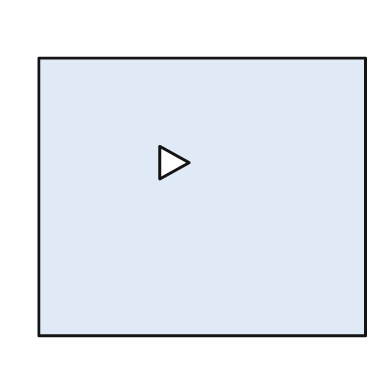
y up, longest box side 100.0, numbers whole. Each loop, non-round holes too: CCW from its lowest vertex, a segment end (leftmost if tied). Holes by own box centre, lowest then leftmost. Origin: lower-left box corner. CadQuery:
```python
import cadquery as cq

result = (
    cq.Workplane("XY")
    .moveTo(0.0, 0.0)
    .lineTo(100.0, 0.0)
    .lineTo(100.0, 85.0)
    .lineTo(0.0, 85.0)
    .close()
    .moveTo(37.0, 48.0)
    .lineTo(46.0, 53.0)
    .lineTo(37.0, 58.0)
    .close()
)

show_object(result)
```